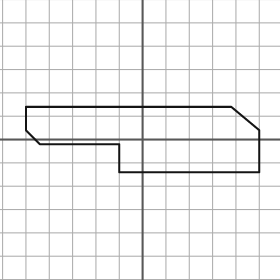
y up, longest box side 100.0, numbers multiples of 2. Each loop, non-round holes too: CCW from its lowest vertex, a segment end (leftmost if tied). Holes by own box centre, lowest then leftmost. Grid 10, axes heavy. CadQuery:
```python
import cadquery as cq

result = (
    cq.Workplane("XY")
    .moveTo(-10.0, -14.0)
    .lineTo(50.0, -14.0)
    .lineTo(50.0, 4.0)
    .lineTo(38.0, 14.0)
    .lineTo(-50.0, 14.0)
    .lineTo(-50.0, 4.0)
    .lineTo(-44.0, -2.0)
    .lineTo(-10.0, -2.0)
    .close()
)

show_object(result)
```